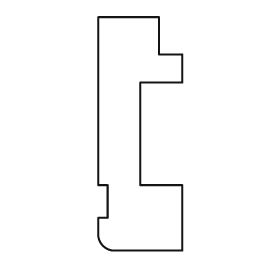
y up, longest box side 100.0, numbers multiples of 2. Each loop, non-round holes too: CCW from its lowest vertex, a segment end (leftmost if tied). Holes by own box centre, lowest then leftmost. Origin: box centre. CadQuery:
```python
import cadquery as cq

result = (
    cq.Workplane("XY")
    .moveTo(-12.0, -50.0)
    .lineTo(18.0, -50.0)
    .lineTo(18.0, -22.0)
    .lineTo(0.0, -22.0)
    .lineTo(0.0, 22.0)
    .lineTo(18.0, 22.0)
    .lineTo(18.0, 34.0)
    .lineTo(8.0, 34.0)
    .lineTo(8.0, 50.0)
    .lineTo(-18.0, 50.0)
    .lineTo(-18.0, -22.0)
    .lineTo(-14.0, -22.0)
    .lineTo(-14.0, -36.0)
    .lineTo(-18.0, -36.0)
    .lineTo(-18.0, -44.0)
    .threePointArc((-16.0, -48.0), (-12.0, -50.0))
    .close()
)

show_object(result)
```